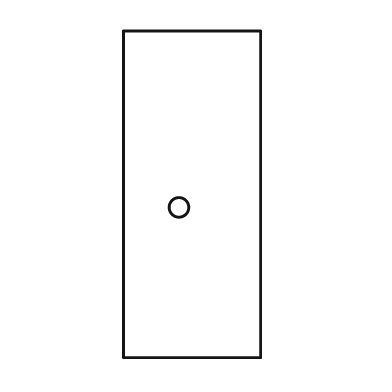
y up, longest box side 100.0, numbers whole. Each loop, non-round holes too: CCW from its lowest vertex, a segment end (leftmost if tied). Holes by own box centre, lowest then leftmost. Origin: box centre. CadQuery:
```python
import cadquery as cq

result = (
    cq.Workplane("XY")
    .moveTo(-21.0, -50.0)
    .lineTo(21.0, -50.0)
    .lineTo(21.0, 50.0)
    .lineTo(-21.0, 50.0)
    .close()
    .moveTo(-4.0, -4.0)
    .circle(3.0)
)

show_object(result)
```